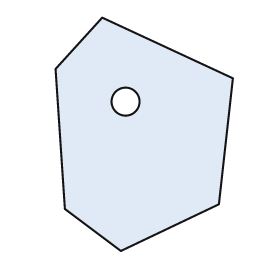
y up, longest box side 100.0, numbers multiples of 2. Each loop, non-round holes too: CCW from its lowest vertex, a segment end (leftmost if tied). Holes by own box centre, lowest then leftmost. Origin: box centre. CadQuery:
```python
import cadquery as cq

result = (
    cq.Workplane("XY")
    .moveTo(-10.0, -50.0)
    .lineTo(32.0, -30.0)
    .lineTo(38.0, 24.0)
    .lineTo(-18.0, 50.0)
    .lineTo(-38.0, 28.0)
    .lineTo(-34.0, -32.0)
    .close()
    .moveTo(-8.0, 14.0)
    .circle(6.0)
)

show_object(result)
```